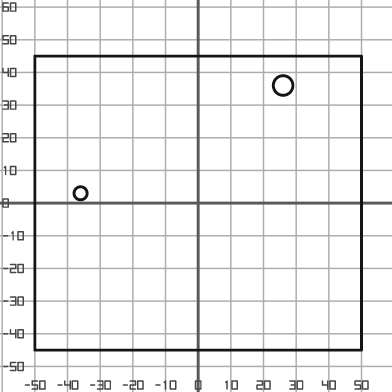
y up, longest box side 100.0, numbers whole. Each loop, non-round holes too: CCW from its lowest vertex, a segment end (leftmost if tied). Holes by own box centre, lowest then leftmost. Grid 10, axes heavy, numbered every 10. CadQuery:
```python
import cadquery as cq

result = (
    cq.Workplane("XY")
    .moveTo(-50.0, -45.0)
    .lineTo(50.0, -45.0)
    .lineTo(50.0, 45.0)
    .lineTo(-50.0, 45.0)
    .close()
    .moveTo(-36.0, 3.0)
    .circle(2.0)
    .moveTo(26.0, 36.0)
    .circle(3.0)
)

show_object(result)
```